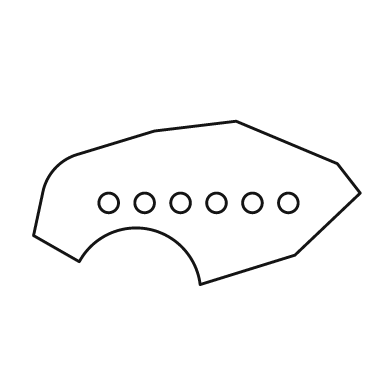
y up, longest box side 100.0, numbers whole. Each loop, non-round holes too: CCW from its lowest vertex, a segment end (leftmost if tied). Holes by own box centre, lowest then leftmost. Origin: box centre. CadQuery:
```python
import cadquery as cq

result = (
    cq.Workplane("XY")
    .moveTo(1.0, -25.0)
    .lineTo(30.0, -16.0)
    .lineTo(50.0, 3.0)
    .lineTo(43.0, 12.0)
    .lineTo(12.0, 25.0)
    .lineTo(-13.0, 22.0)
    .lineTo(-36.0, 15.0)
    .threePointArc((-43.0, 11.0), (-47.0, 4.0))
    .lineTo(-50.0, -10.0)
    .lineTo(-36.0, -18.0)
    .threePointArc((-15.0, -8.0), (1.0, -25.0))
    .close()
    .moveTo(-27.0, 0.0)
    .circle(3.0)
    .moveTo(-16.0, 0.0)
    .circle(3.0)
    .moveTo(-5.0, 0.0)
    .circle(3.0)
    .moveTo(6.0, 0.0)
    .circle(3.0)
    .moveTo(17.0, 0.0)
    .circle(3.0)
    .moveTo(28.0, 0.0)
    .circle(3.0)
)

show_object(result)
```